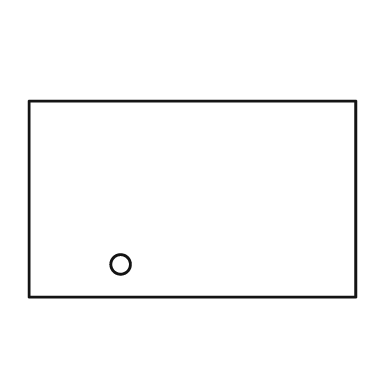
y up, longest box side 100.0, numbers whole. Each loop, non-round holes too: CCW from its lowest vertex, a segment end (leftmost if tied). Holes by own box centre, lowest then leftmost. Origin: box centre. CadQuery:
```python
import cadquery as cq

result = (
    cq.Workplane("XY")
    .moveTo(-50.0, -30.0)
    .lineTo(50.0, -30.0)
    .lineTo(50.0, 30.0)
    .lineTo(-50.0, 30.0)
    .close()
    .moveTo(-22.0, -20.0)
    .circle(3.0)
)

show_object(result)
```